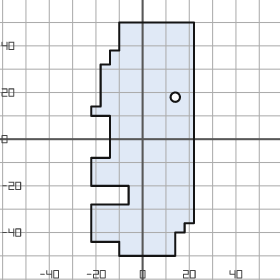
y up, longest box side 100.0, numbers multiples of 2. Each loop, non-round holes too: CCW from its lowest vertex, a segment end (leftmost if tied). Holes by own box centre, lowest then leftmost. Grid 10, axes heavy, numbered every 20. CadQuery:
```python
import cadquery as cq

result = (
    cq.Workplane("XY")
    .moveTo(-10.0, -50.0)
    .lineTo(14.0, -50.0)
    .lineTo(14.0, -40.0)
    .lineTo(18.0, -40.0)
    .lineTo(18.0, -36.0)
    .lineTo(22.0, -36.0)
    .lineTo(22.0, 50.0)
    .lineTo(-10.0, 50.0)
    .lineTo(-10.0, 38.0)
    .lineTo(-14.0, 38.0)
    .lineTo(-14.0, 32.0)
    .lineTo(-18.0, 32.0)
    .lineTo(-18.0, 14.0)
    .lineTo(-22.0, 14.0)
    .lineTo(-22.0, 10.0)
    .lineTo(-14.0, 10.0)
    .lineTo(-14.0, -8.0)
    .lineTo(-22.0, -8.0)
    .lineTo(-22.0, -20.0)
    .lineTo(-6.0, -20.0)
    .lineTo(-6.0, -28.0)
    .lineTo(-22.0, -28.0)
    .lineTo(-22.0, -44.0)
    .lineTo(-10.0, -44.0)
    .close()
    .moveTo(14.0, 18.0)
    .circle(2.0)
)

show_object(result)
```